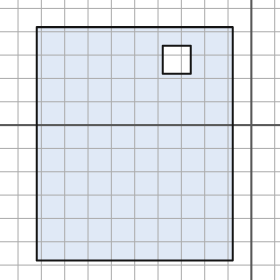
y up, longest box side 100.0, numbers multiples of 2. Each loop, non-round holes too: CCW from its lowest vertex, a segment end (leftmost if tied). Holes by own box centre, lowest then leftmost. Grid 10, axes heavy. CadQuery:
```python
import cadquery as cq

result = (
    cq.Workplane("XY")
    .moveTo(-92.0, -58.0)
    .lineTo(-8.0, -58.0)
    .lineTo(-8.0, 42.0)
    .lineTo(-92.0, 42.0)
    .close()
    .moveTo(-38.0, 22.0)
    .lineTo(-26.0, 22.0)
    .lineTo(-26.0, 34.0)
    .lineTo(-38.0, 34.0)
    .close()
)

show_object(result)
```